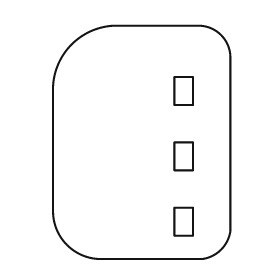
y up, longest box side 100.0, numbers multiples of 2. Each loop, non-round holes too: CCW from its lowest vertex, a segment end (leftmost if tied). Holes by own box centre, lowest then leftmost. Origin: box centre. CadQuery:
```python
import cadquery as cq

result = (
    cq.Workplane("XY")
    .moveTo(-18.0, -50.0)
    .lineTo(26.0, -50.0)
    .threePointArc((34.0, -46.0), (38.0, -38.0))
    .lineTo(38.0, 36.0)
    .threePointArc((34.0, 46.0), (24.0, 50.0))
    .lineTo(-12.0, 50.0)
    .threePointArc((-30.0, 42.0), (-38.0, 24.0))
    .lineTo(-38.0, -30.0)
    .threePointArc((-32.0, -44.0), (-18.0, -50.0))
    .close()
    .moveTo(14.0, -40.0)
    .lineTo(22.0, -40.0)
    .lineTo(22.0, -28.0)
    .lineTo(14.0, -28.0)
    .close()
    .moveTo(14.0, -12.0)
    .lineTo(22.0, -12.0)
    .lineTo(22.0, 0.0)
    .lineTo(14.0, 0.0)
    .close()
    .moveTo(14.0, 16.0)
    .lineTo(22.0, 16.0)
    .lineTo(22.0, 28.0)
    .lineTo(14.0, 28.0)
    .close()
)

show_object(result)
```